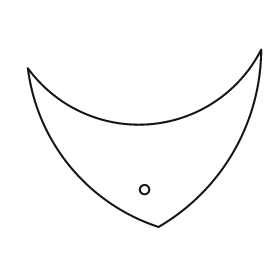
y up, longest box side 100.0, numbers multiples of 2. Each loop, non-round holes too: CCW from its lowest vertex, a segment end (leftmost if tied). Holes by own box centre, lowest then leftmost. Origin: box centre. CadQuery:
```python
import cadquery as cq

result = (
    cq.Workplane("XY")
    .moveTo(6.0, -38.0)
    .threePointArc((38.0, -6.0), (50.0, 38.0))
    .threePointArc((2.0, 6.0), (-50.0, 30.0))
    .threePointArc((-32.0, -12.0), (6.0, -38.0))
    .close()
    .moveTo(0.0, -22.0)
    .circle(2.0)
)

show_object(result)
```